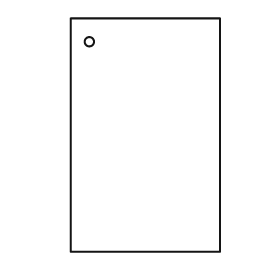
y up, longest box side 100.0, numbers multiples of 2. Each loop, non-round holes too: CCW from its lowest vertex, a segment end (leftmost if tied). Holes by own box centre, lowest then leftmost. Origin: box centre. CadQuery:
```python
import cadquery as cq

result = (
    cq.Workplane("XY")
    .moveTo(-32.0, -50.0)
    .lineTo(32.0, -50.0)
    .lineTo(32.0, 50.0)
    .lineTo(-32.0, 50.0)
    .close()
    .moveTo(-24.0, 40.0)
    .circle(2.0)
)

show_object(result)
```